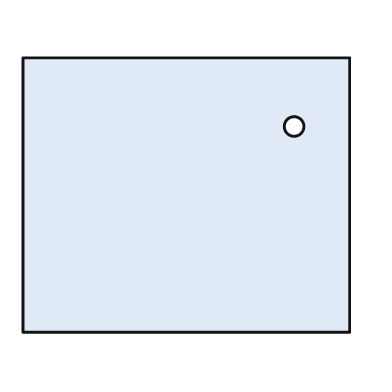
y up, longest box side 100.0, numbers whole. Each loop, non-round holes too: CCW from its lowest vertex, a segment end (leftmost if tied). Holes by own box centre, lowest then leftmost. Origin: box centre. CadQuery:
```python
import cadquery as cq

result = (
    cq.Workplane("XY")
    .moveTo(-50.0, -42.0)
    .lineTo(50.0, -42.0)
    .lineTo(50.0, 42.0)
    .lineTo(-50.0, 42.0)
    .close()
    .moveTo(33.0, 21.0)
    .circle(3.0)
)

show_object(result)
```